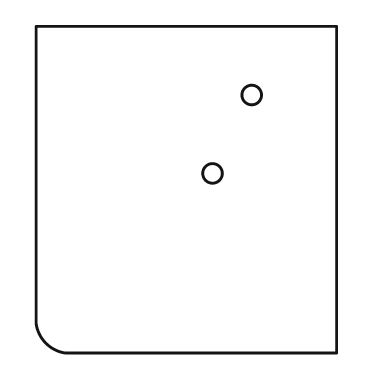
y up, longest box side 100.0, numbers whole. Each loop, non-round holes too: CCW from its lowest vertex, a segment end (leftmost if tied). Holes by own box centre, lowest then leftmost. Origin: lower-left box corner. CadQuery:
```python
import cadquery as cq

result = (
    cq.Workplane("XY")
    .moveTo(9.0, 0.0)
    .lineTo(92.0, 0.0)
    .lineTo(92.0, 100.0)
    .lineTo(0.0, 100.0)
    .lineTo(0.0, 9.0)
    .threePointArc((3.0, 3.0), (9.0, 0.0))
    .close()
    .moveTo(54.0, 55.0)
    .circle(3.0)
    .moveTo(66.0, 79.0)
    .circle(3.0)
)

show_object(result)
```